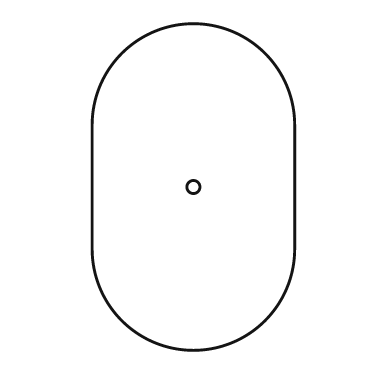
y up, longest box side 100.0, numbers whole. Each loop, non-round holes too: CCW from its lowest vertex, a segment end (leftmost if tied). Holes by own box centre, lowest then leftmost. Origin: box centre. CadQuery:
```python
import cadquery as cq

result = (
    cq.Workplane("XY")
    .moveTo(-31.0, -19.0)
    .threePointArc((0.0, -50.0), (31.0, -19.0))
    .lineTo(31.0, 19.0)
    .threePointArc((0.0, 50.0), (-31.0, 19.0))
    .close()
    .moveTo(0.0, 0.0)
    .circle(2.0)
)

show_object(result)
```